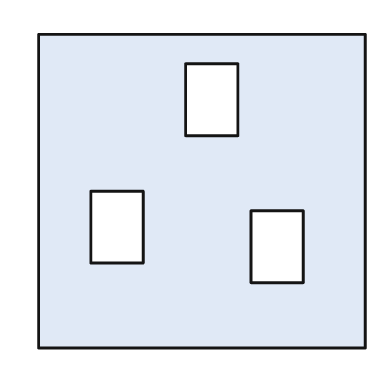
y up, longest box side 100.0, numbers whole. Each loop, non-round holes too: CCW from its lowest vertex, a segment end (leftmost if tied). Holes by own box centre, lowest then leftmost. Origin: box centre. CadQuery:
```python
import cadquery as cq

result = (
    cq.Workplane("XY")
    .moveTo(-50.0, -48.0)
    .lineTo(50.0, -48.0)
    .lineTo(50.0, 48.0)
    .lineTo(-50.0, 48.0)
    .close()
    .moveTo(15.0, -28.0)
    .lineTo(31.0, -28.0)
    .lineTo(31.0, -6.0)
    .lineTo(15.0, -6.0)
    .close()
    .moveTo(-34.0, -22.0)
    .lineTo(-18.0, -22.0)
    .lineTo(-18.0, 0.0)
    .lineTo(-34.0, 0.0)
    .close()
    .moveTo(-5.0, 17.0)
    .lineTo(11.0, 17.0)
    .lineTo(11.0, 39.0)
    .lineTo(-5.0, 39.0)
    .close()
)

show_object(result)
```